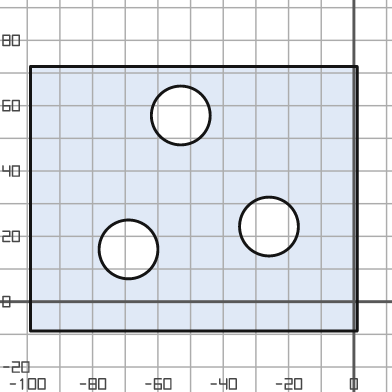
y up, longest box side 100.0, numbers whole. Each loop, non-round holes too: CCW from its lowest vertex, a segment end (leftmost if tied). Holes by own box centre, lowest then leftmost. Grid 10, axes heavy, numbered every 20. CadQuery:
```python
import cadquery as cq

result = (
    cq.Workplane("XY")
    .moveTo(-99.0, -9.0)
    .lineTo(1.0, -9.0)
    .lineTo(1.0, 72.0)
    .lineTo(-99.0, 72.0)
    .close()
    .moveTo(-69.0, 16.0)
    .circle(9.0)
    .moveTo(-26.0, 23.0)
    .circle(9.0)
    .moveTo(-53.0, 57.0)
    .circle(9.0)
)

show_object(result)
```